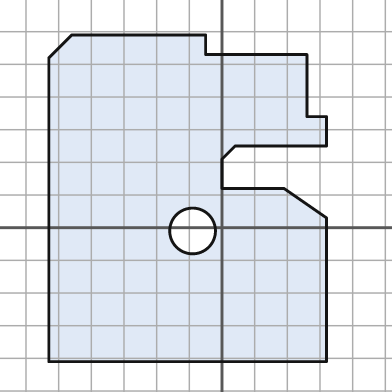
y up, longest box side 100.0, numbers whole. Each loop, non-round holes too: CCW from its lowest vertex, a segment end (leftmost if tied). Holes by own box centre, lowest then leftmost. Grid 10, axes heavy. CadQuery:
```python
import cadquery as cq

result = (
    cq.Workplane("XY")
    .moveTo(-53.0, -41.0)
    .lineTo(32.0, -41.0)
    .lineTo(32.0, 3.0)
    .lineTo(19.0, 12.0)
    .lineTo(0.0, 12.0)
    .lineTo(0.0, 21.0)
    .lineTo(4.0, 25.0)
    .lineTo(32.0, 25.0)
    .lineTo(32.0, 34.0)
    .lineTo(26.0, 34.0)
    .lineTo(26.0, 53.0)
    .lineTo(-5.0, 53.0)
    .lineTo(-5.0, 59.0)
    .lineTo(-46.0, 59.0)
    .lineTo(-53.0, 52.0)
    .close()
    .moveTo(-9.0, -1.0)
    .circle(7.0)
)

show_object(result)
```